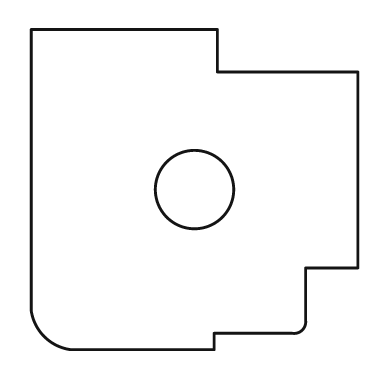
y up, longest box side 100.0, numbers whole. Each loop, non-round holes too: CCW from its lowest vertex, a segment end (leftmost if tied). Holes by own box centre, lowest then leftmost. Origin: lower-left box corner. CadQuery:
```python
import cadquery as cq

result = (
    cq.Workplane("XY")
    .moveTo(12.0, 0.0)
    .lineTo(56.0, 0.0)
    .lineTo(56.0, 5.0)
    .lineTo(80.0, 5.0)
    .threePointArc((83.0, 6.0), (84.0, 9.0))
    .lineTo(84.0, 25.0)
    .lineTo(100.0, 25.0)
    .lineTo(100.0, 85.0)
    .lineTo(57.0, 85.0)
    .lineTo(57.0, 98.0)
    .lineTo(0.0, 98.0)
    .lineTo(0.0, 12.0)
    .threePointArc((4.0, 4.0), (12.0, 0.0))
    .close()
    .moveTo(50.0, 49.0)
    .circle(12.0)
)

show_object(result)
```